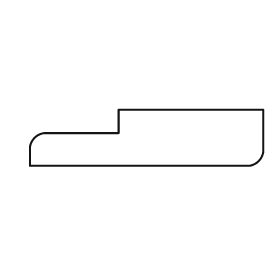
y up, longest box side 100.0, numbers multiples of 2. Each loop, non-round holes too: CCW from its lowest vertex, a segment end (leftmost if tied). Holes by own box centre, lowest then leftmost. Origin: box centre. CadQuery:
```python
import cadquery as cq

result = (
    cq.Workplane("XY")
    .moveTo(-50.0, -12.0)
    .lineTo(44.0, -12.0)
    .threePointArc((48.0, -10.0), (50.0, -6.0))
    .lineTo(50.0, 12.0)
    .lineTo(-12.0, 12.0)
    .lineTo(-12.0, 2.0)
    .lineTo(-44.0, 2.0)
    .threePointArc((-48.0, 0.0), (-50.0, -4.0))
    .close()
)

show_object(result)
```